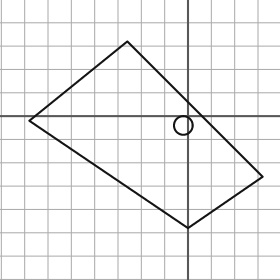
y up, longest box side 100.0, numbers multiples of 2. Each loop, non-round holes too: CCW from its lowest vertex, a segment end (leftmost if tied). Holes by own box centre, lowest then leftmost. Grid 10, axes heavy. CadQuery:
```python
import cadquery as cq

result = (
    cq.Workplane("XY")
    .moveTo(0.0, -48.0)
    .lineTo(32.0, -26.0)
    .lineTo(-26.0, 32.0)
    .lineTo(-68.0, -2.0)
    .close()
    .moveTo(-2.0, -4.0)
    .circle(4.0)
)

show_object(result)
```